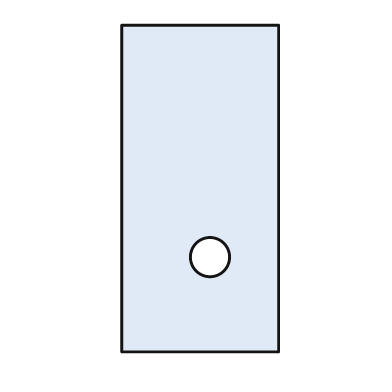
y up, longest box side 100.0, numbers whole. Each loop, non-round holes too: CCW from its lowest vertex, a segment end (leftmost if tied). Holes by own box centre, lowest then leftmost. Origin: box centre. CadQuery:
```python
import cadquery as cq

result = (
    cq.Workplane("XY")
    .moveTo(-24.0, -50.0)
    .lineTo(24.0, -50.0)
    .lineTo(24.0, 50.0)
    .lineTo(-24.0, 50.0)
    .close()
    .moveTo(3.0, -21.0)
    .circle(6.0)
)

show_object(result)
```